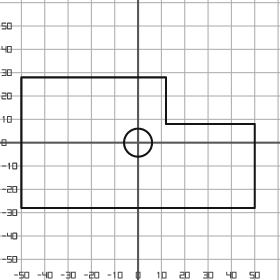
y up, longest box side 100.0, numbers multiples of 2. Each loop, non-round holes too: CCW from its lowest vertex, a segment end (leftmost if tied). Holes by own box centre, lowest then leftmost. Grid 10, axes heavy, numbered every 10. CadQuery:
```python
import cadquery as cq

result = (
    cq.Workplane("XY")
    .moveTo(-50.0, -28.0)
    .lineTo(50.0, -28.0)
    .lineTo(50.0, 8.0)
    .lineTo(12.0, 8.0)
    .lineTo(12.0, 28.0)
    .lineTo(-50.0, 28.0)
    .close()
    .moveTo(0.0, 0.0)
    .circle(6.0)
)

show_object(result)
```